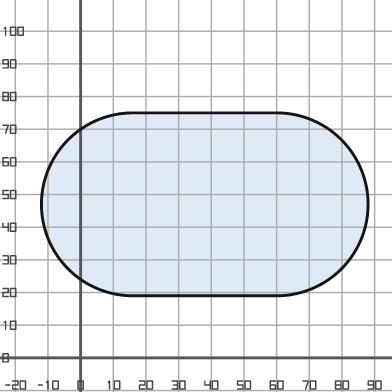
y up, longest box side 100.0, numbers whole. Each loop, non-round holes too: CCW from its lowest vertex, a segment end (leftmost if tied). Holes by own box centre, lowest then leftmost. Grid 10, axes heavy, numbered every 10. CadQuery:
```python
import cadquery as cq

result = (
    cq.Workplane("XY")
    .moveTo(16.0, 19.0)
    .lineTo(60.0, 19.0)
    .threePointArc((88.0, 47.0), (60.0, 75.0))
    .lineTo(16.0, 75.0)
    .threePointArc((-12.0, 47.0), (16.0, 19.0))
    .close()
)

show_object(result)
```